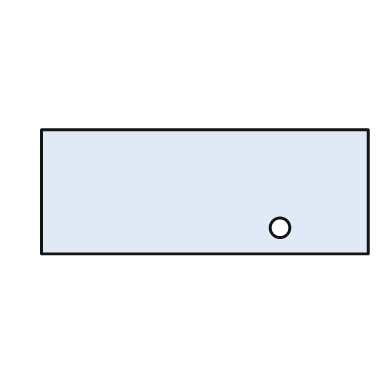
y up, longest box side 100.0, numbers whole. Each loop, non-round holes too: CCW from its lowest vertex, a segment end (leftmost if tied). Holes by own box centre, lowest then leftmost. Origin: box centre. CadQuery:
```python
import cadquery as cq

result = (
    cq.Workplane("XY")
    .moveTo(-50.0, -19.0)
    .lineTo(50.0, -19.0)
    .lineTo(50.0, 19.0)
    .lineTo(-50.0, 19.0)
    .close()
    .moveTo(23.0, -11.0)
    .circle(3.0)
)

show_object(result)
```